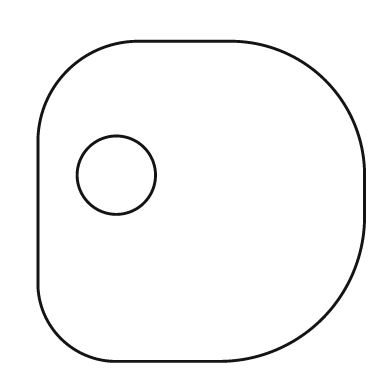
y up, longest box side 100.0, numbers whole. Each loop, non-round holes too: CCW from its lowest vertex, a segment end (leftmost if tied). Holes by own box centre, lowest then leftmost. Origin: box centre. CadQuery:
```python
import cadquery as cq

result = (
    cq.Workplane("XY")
    .moveTo(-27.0, -49.0)
    .lineTo(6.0, -49.0)
    .threePointArc((37.0, -36.0), (50.0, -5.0))
    .lineTo(50.0, 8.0)
    .threePointArc((38.0, 37.0), (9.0, 49.0))
    .lineTo(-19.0, 49.0)
    .threePointArc((-41.0, 40.0), (-50.0, 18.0))
    .lineTo(-50.0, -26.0)
    .threePointArc((-43.0, -42.0), (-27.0, -49.0))
    .close()
    .moveTo(-26.0, 8.0)
    .circle(12.0)
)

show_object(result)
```